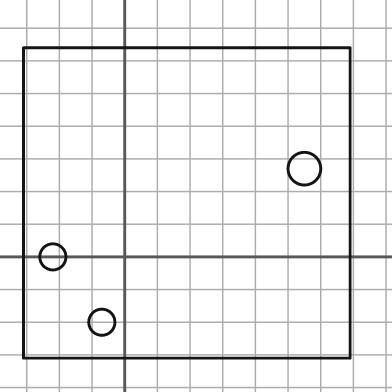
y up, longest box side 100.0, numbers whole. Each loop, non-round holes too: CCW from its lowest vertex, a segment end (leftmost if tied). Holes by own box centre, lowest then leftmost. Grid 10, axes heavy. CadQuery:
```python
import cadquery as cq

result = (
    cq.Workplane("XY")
    .moveTo(-31.0, -31.0)
    .lineTo(69.0, -31.0)
    .lineTo(69.0, 64.0)
    .lineTo(-31.0, 64.0)
    .close()
    .moveTo(-7.0, -20.0)
    .circle(4.0)
    .moveTo(-22.0, 0.0)
    .circle(4.0)
    .moveTo(55.0, 27.0)
    .circle(5.0)
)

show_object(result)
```